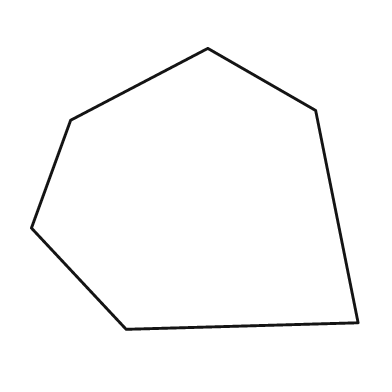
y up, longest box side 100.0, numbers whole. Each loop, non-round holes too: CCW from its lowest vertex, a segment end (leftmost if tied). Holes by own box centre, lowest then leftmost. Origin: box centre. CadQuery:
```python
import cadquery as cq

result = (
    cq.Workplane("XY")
    .moveTo(-21.0, -43.0)
    .lineTo(50.0, -41.0)
    .lineTo(37.0, 24.0)
    .lineTo(4.0, 43.0)
    .lineTo(-38.0, 21.0)
    .lineTo(-50.0, -12.0)
    .close()
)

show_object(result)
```